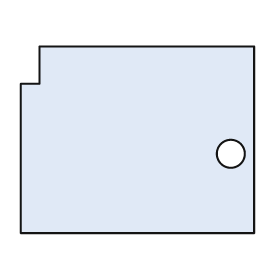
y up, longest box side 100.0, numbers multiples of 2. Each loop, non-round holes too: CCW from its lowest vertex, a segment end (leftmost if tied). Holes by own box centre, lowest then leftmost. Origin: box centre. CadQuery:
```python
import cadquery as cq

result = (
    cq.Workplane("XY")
    .moveTo(-50.0, -40.0)
    .lineTo(50.0, -40.0)
    .lineTo(50.0, 40.0)
    .lineTo(-42.0, 40.0)
    .lineTo(-42.0, 24.0)
    .lineTo(-50.0, 24.0)
    .close()
    .moveTo(40.0, -6.0)
    .circle(6.0)
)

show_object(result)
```